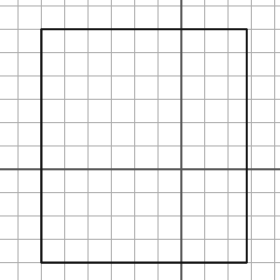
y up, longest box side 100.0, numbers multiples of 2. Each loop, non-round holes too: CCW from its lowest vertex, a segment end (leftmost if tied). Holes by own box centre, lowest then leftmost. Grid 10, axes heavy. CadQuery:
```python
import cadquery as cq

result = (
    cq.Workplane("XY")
    .moveTo(-60.0, -40.0)
    .lineTo(28.0, -40.0)
    .lineTo(28.0, 60.0)
    .lineTo(-60.0, 60.0)
    .close()
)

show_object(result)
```